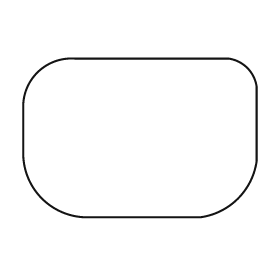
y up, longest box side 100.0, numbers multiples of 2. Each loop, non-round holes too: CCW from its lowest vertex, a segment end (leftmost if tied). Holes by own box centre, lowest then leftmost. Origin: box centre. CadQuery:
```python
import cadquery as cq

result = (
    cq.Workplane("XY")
    .moveTo(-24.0, -34.0)
    .lineTo(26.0, -34.0)
    .threePointArc((42.0, -26.0), (50.0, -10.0))
    .lineTo(50.0, 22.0)
    .threePointArc((46.0, 30.0), (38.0, 34.0))
    .lineTo(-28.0, 34.0)
    .threePointArc((-44.0, 28.0), (-50.0, 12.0))
    .lineTo(-50.0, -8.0)
    .threePointArc((-42.0, -26.0), (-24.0, -34.0))
    .close()
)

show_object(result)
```